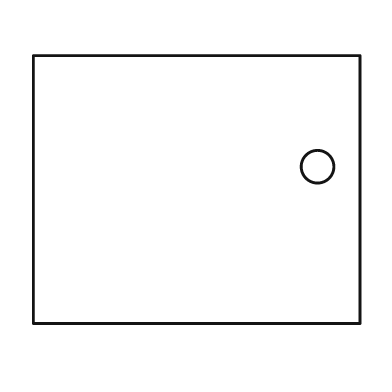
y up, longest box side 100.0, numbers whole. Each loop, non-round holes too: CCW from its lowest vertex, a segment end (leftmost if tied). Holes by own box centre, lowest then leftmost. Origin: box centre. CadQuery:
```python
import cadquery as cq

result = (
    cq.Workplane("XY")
    .moveTo(-50.0, -41.0)
    .lineTo(50.0, -41.0)
    .lineTo(50.0, 41.0)
    .lineTo(-50.0, 41.0)
    .close()
    .moveTo(37.0, 7.0)
    .circle(5.0)
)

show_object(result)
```